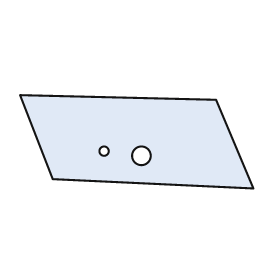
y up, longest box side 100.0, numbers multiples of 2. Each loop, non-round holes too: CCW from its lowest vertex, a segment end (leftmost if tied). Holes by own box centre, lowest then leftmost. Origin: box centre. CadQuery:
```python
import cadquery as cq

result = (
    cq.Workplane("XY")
    .moveTo(50.0, -20.0)
    .lineTo(34.0, 18.0)
    .lineTo(-50.0, 20.0)
    .lineTo(-36.0, -16.0)
    .close()
    .moveTo(2.0, -6.0)
    .circle(4.0)
    .moveTo(-14.0, -4.0)
    .circle(2.0)
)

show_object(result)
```